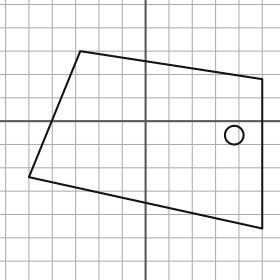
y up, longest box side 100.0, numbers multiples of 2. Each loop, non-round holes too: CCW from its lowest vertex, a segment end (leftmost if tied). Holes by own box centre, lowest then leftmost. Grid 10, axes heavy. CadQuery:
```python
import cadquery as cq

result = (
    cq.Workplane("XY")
    .moveTo(50.0, -46.0)
    .lineTo(50.0, 18.0)
    .lineTo(-28.0, 30.0)
    .lineTo(-50.0, -24.0)
    .close()
    .moveTo(38.0, -6.0)
    .circle(4.0)
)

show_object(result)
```